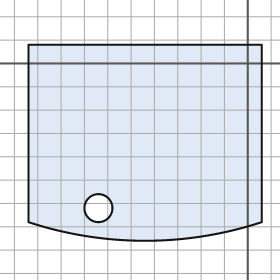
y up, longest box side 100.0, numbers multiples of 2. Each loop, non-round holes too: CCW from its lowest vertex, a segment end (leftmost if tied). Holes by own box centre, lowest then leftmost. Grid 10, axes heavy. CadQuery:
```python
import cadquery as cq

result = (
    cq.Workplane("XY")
    .moveTo(-94.0, -68.0)
    .threePointArc((-44.0, -76.0), (6.0, -68.0))
    .lineTo(6.0, 8.0)
    .lineTo(-94.0, 8.0)
    .close()
    .moveTo(-64.0, -62.0)
    .circle(6.0)
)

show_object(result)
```